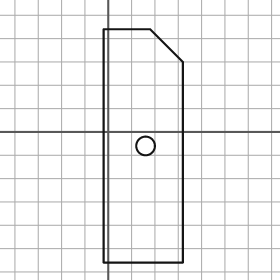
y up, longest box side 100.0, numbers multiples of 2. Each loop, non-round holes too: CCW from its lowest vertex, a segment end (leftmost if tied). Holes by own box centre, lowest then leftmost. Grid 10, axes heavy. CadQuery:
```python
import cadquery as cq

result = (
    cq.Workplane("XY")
    .moveTo(-2.0, -56.0)
    .lineTo(32.0, -56.0)
    .lineTo(32.0, 30.0)
    .lineTo(18.0, 44.0)
    .lineTo(-2.0, 44.0)
    .close()
    .moveTo(16.0, -6.0)
    .circle(4.0)
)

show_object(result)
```